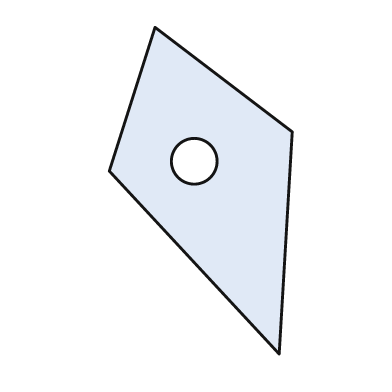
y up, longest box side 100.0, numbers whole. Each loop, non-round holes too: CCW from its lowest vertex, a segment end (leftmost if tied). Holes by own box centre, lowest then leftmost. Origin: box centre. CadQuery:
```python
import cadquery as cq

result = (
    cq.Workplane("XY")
    .moveTo(24.0, -50.0)
    .lineTo(28.0, 18.0)
    .lineTo(-14.0, 50.0)
    .lineTo(-28.0, 6.0)
    .close()
    .moveTo(-2.0, 9.0)
    .circle(7.0)
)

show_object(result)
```